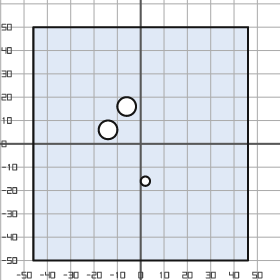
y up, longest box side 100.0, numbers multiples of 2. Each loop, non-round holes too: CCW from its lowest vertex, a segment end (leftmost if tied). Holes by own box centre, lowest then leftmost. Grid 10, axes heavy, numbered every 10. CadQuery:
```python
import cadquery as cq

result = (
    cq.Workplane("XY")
    .moveTo(-46.0, -50.0)
    .lineTo(46.0, -50.0)
    .lineTo(46.0, 50.0)
    .lineTo(-46.0, 50.0)
    .close()
    .moveTo(2.0, -16.0)
    .circle(2.0)
    .moveTo(-14.0, 6.0)
    .circle(4.0)
    .moveTo(-6.0, 16.0)
    .circle(4.0)
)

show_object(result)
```